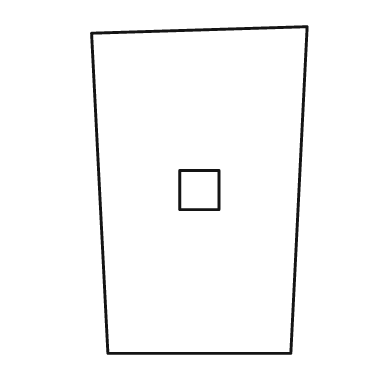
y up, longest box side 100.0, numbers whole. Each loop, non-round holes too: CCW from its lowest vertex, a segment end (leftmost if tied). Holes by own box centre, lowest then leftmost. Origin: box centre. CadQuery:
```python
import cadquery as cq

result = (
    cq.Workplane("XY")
    .moveTo(-28.0, -50.0)
    .lineTo(28.0, -50.0)
    .lineTo(33.0, 50.0)
    .lineTo(-33.0, 48.0)
    .close()
    .moveTo(-6.0, -6.0)
    .lineTo(6.0, -6.0)
    .lineTo(6.0, 6.0)
    .lineTo(-6.0, 6.0)
    .close()
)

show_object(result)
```